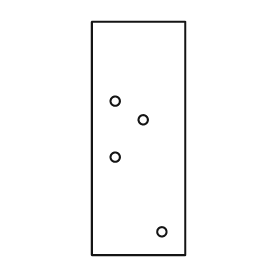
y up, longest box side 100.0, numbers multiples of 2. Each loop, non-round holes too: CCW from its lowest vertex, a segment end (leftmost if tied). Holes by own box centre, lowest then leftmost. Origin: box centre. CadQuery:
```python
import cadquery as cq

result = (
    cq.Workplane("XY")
    .moveTo(-20.0, -50.0)
    .lineTo(20.0, -50.0)
    .lineTo(20.0, 50.0)
    .lineTo(-20.0, 50.0)
    .close()
    .moveTo(10.0, -40.0)
    .circle(2.0)
    .moveTo(-10.0, -8.0)
    .circle(2.0)
    .moveTo(2.0, 8.0)
    .circle(2.0)
    .moveTo(-10.0, 16.0)
    .circle(2.0)
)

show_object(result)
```